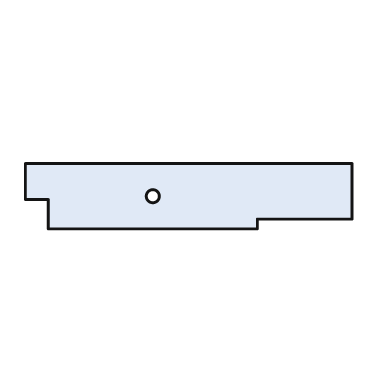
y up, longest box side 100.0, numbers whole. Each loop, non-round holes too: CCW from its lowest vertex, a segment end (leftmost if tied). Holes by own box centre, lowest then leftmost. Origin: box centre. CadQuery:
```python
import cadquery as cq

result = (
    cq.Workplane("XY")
    .moveTo(-43.0, -10.0)
    .lineTo(21.0, -10.0)
    .lineTo(21.0, -7.0)
    .lineTo(50.0, -7.0)
    .lineTo(50.0, 10.0)
    .lineTo(-50.0, 10.0)
    .lineTo(-50.0, -1.0)
    .lineTo(-43.0, -1.0)
    .close()
    .moveTo(-11.0, 0.0)
    .circle(2.0)
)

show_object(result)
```